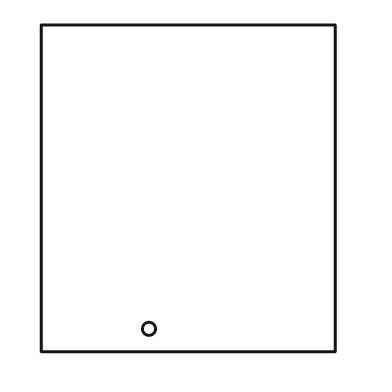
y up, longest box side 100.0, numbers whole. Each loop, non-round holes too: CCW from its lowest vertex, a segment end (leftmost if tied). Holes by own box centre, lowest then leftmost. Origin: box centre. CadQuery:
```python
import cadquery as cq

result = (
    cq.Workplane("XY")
    .moveTo(-45.0, -50.0)
    .lineTo(45.0, -50.0)
    .lineTo(45.0, 50.0)
    .lineTo(-45.0, 50.0)
    .close()
    .moveTo(-12.0, -43.0)
    .circle(2.0)
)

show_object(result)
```